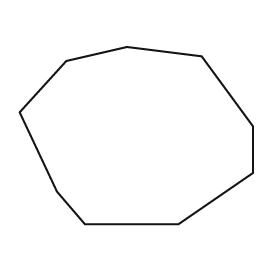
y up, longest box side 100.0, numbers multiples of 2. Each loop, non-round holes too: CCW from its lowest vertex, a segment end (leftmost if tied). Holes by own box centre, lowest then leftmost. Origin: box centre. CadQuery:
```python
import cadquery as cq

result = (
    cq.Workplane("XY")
    .moveTo(-22.0, -38.0)
    .lineTo(18.0, -38.0)
    .lineTo(50.0, -16.0)
    .lineTo(50.0, 4.0)
    .lineTo(28.0, 34.0)
    .lineTo(-4.0, 38.0)
    .lineTo(-30.0, 32.0)
    .lineTo(-50.0, 10.0)
    .lineTo(-34.0, -24.0)
    .close()
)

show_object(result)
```